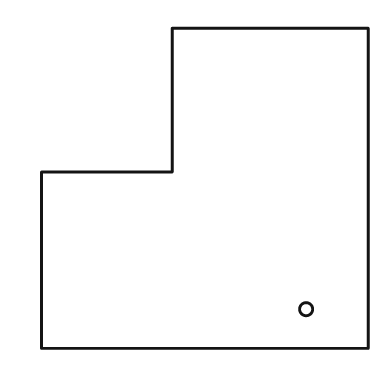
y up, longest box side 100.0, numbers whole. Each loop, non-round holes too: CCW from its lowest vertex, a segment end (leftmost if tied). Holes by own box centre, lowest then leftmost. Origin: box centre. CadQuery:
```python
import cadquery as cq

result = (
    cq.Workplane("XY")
    .moveTo(-50.0, -49.0)
    .lineTo(50.0, -49.0)
    .lineTo(50.0, 49.0)
    .lineTo(-10.0, 49.0)
    .lineTo(-10.0, 5.0)
    .lineTo(-50.0, 5.0)
    .close()
    .moveTo(31.0, -37.0)
    .circle(2.0)
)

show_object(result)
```